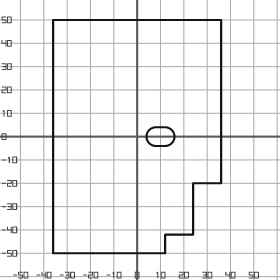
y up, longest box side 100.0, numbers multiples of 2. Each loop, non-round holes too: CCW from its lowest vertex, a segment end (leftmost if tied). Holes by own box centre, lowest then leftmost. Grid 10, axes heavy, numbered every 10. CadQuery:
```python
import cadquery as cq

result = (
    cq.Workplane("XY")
    .moveTo(-36.0, -50.0)
    .lineTo(12.0, -50.0)
    .lineTo(12.0, -42.0)
    .lineTo(24.0, -42.0)
    .lineTo(24.0, -20.0)
    .lineTo(36.0, -20.0)
    .lineTo(36.0, 50.0)
    .lineTo(-36.0, 50.0)
    .close()
    .moveTo(8.0, -4.0)
    .lineTo(12.0, -4.0)
    .threePointArc((16.0, 0.0), (12.0, 4.0))
    .lineTo(8.0, 4.0)
    .threePointArc((4.0, 0.0), (8.0, -4.0))
    .close()
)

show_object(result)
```